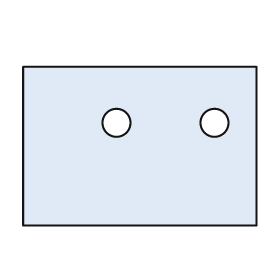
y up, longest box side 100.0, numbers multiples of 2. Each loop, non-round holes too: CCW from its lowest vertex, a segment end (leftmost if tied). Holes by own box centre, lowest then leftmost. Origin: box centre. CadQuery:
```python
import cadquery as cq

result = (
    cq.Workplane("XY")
    .moveTo(-50.0, -34.0)
    .lineTo(50.0, -34.0)
    .lineTo(50.0, 34.0)
    .lineTo(-50.0, 34.0)
    .close()
    .moveTo(-10.0, 10.0)
    .circle(6.0)
    .moveTo(32.0, 10.0)
    .circle(6.0)
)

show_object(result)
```